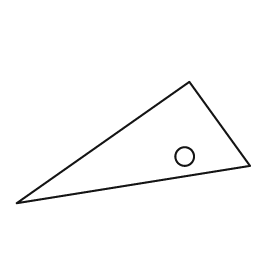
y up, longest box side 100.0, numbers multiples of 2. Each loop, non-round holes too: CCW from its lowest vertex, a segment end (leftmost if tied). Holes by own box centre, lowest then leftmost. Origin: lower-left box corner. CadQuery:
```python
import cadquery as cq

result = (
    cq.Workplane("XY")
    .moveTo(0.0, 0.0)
    .lineTo(100.0, 16.0)
    .lineTo(74.0, 52.0)
    .close()
    .moveTo(72.0, 20.0)
    .circle(4.0)
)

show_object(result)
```